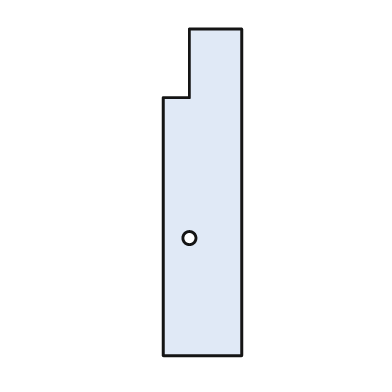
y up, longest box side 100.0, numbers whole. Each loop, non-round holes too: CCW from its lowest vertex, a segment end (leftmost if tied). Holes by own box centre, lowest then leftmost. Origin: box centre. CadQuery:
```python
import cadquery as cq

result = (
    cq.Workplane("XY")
    .moveTo(-12.0, -50.0)
    .lineTo(12.0, -50.0)
    .lineTo(12.0, 50.0)
    .lineTo(-4.0, 50.0)
    .lineTo(-4.0, 29.0)
    .lineTo(-12.0, 29.0)
    .close()
    .moveTo(-4.0, -14.0)
    .circle(2.0)
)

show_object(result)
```